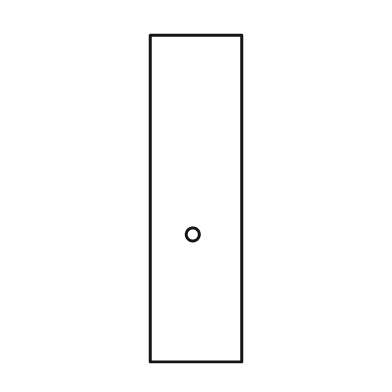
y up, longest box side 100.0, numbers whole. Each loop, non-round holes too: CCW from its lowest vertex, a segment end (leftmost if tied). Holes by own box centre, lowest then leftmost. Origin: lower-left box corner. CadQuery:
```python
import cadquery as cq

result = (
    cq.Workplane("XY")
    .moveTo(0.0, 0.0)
    .lineTo(28.0, 0.0)
    .lineTo(28.0, 100.0)
    .lineTo(0.0, 100.0)
    .close()
    .moveTo(13.0, 39.0)
    .circle(2.0)
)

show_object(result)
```